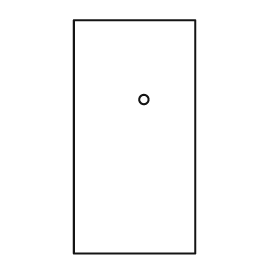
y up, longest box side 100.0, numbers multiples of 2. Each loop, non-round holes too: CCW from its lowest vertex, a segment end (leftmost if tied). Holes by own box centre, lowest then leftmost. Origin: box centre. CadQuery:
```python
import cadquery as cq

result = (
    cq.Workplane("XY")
    .moveTo(-26.0, -50.0)
    .lineTo(26.0, -50.0)
    .lineTo(26.0, 50.0)
    .lineTo(-26.0, 50.0)
    .close()
    .moveTo(4.0, 16.0)
    .circle(2.0)
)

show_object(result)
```